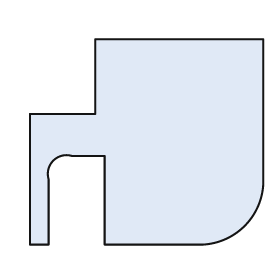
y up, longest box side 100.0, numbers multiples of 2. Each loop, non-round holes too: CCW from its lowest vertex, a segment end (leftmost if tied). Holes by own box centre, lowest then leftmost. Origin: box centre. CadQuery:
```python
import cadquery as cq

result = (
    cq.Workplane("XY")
    .moveTo(-50.0, -44.0)
    .lineTo(-42.0, -44.0)
    .lineTo(-42.0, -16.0)
    .threePointArc((-40.0, -8.0), (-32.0, -6.0))
    .lineTo(-18.0, -6.0)
    .lineTo(-18.0, -44.0)
    .lineTo(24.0, -44.0)
    .threePointArc((42.0, -36.0), (50.0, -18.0))
    .lineTo(50.0, 44.0)
    .lineTo(-22.0, 44.0)
    .lineTo(-22.0, 12.0)
    .lineTo(-50.0, 12.0)
    .close()
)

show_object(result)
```